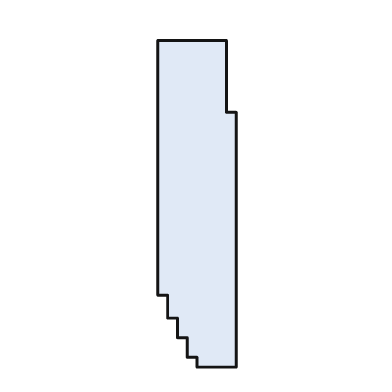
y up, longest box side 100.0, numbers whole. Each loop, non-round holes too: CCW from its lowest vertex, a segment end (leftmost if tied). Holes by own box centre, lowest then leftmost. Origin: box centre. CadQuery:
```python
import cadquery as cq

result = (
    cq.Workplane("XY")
    .moveTo(0.0, -50.0)
    .lineTo(12.0, -50.0)
    .lineTo(12.0, 28.0)
    .lineTo(9.0, 28.0)
    .lineTo(9.0, 50.0)
    .lineTo(-12.0, 50.0)
    .lineTo(-12.0, -28.0)
    .lineTo(-9.0, -28.0)
    .lineTo(-9.0, -35.0)
    .lineTo(-6.0, -35.0)
    .lineTo(-6.0, -41.0)
    .lineTo(-3.0, -41.0)
    .lineTo(-3.0, -47.0)
    .lineTo(0.0, -47.0)
    .close()
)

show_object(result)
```